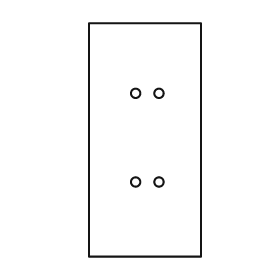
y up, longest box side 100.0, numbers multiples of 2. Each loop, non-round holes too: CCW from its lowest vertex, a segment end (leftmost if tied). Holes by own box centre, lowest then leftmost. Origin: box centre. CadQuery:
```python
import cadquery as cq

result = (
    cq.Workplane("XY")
    .moveTo(-24.0, -50.0)
    .lineTo(24.0, -50.0)
    .lineTo(24.0, 50.0)
    .lineTo(-24.0, 50.0)
    .close()
    .moveTo(-4.0, -18.0)
    .circle(2.0)
    .moveTo(6.0, -18.0)
    .circle(2.0)
    .moveTo(-4.0, 20.0)
    .circle(2.0)
    .moveTo(6.0, 20.0)
    .circle(2.0)
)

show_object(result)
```